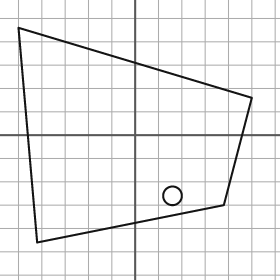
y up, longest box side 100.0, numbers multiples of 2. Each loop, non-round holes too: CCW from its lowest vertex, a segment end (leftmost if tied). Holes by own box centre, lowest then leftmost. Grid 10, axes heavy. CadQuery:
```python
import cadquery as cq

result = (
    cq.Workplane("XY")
    .moveTo(-42.0, -46.0)
    .lineTo(38.0, -30.0)
    .lineTo(50.0, 16.0)
    .lineTo(-50.0, 46.0)
    .close()
    .moveTo(16.0, -26.0)
    .circle(4.0)
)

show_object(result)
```